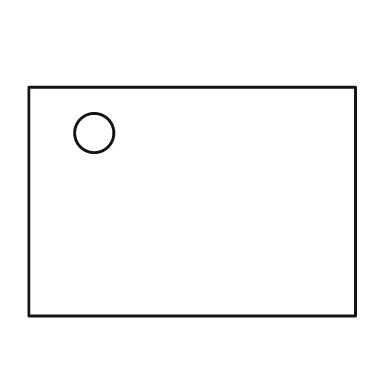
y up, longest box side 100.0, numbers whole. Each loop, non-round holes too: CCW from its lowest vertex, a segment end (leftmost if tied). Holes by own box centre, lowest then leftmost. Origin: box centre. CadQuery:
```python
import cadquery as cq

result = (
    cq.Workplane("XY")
    .moveTo(-50.0, -35.0)
    .lineTo(50.0, -35.0)
    .lineTo(50.0, 35.0)
    .lineTo(-50.0, 35.0)
    .close()
    .moveTo(-30.0, 21.0)
    .circle(6.0)
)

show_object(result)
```